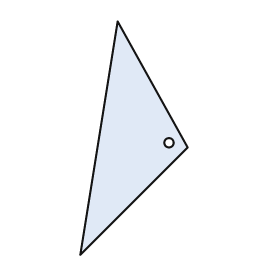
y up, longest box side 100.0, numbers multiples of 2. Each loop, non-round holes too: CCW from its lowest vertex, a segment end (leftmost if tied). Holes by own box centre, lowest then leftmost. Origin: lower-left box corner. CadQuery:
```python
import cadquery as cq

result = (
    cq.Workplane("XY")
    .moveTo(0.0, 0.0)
    .lineTo(46.0, 46.0)
    .lineTo(16.0, 100.0)
    .close()
    .moveTo(38.0, 48.0)
    .circle(2.0)
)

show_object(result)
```